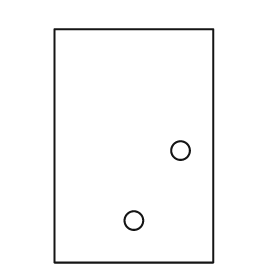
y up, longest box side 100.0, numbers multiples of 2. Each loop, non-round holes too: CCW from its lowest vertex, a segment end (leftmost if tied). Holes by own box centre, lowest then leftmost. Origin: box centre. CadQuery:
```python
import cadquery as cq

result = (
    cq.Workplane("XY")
    .moveTo(-34.0, -50.0)
    .lineTo(34.0, -50.0)
    .lineTo(34.0, 50.0)
    .lineTo(-34.0, 50.0)
    .close()
    .moveTo(0.0, -32.0)
    .circle(4.0)
    .moveTo(20.0, -2.0)
    .circle(4.0)
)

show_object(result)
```